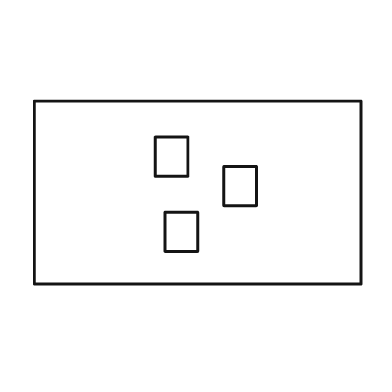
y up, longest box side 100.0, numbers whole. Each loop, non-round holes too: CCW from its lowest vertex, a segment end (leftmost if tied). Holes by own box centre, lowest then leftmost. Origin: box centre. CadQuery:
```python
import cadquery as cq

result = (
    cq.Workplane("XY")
    .moveTo(-50.0, -28.0)
    .lineTo(50.0, -28.0)
    .lineTo(50.0, 28.0)
    .lineTo(-50.0, 28.0)
    .close()
    .moveTo(-10.0, -18.0)
    .lineTo(0.0, -18.0)
    .lineTo(0.0, -6.0)
    .lineTo(-10.0, -6.0)
    .close()
    .moveTo(8.0, -4.0)
    .lineTo(18.0, -4.0)
    .lineTo(18.0, 8.0)
    .lineTo(8.0, 8.0)
    .close()
    .moveTo(-13.0, 5.0)
    .lineTo(-3.0, 5.0)
    .lineTo(-3.0, 17.0)
    .lineTo(-13.0, 17.0)
    .close()
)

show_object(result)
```